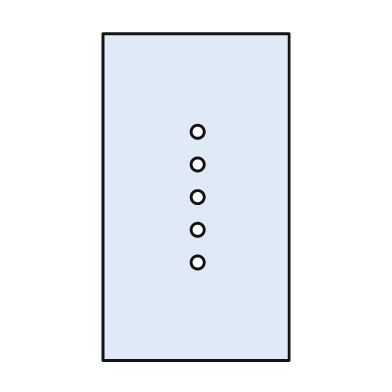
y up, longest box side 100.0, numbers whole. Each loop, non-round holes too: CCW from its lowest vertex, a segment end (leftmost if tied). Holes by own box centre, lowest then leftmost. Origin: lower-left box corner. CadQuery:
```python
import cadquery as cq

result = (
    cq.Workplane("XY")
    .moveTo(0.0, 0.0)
    .lineTo(57.0, 0.0)
    .lineTo(57.0, 100.0)
    .lineTo(0.0, 100.0)
    .close()
    .moveTo(29.0, 30.0)
    .circle(2.0)
    .moveTo(29.0, 40.0)
    .circle(2.0)
    .moveTo(29.0, 50.0)
    .circle(2.0)
    .moveTo(29.0, 60.0)
    .circle(2.0)
    .moveTo(29.0, 70.0)
    .circle(2.0)
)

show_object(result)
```